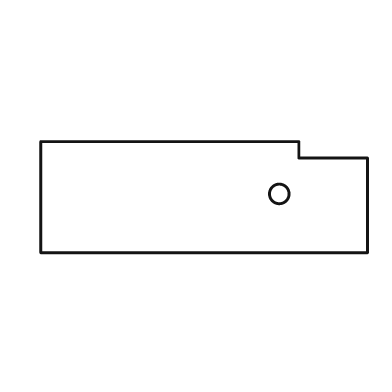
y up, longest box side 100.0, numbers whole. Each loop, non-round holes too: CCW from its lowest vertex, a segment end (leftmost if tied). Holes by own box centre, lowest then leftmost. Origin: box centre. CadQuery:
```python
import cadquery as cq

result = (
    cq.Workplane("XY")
    .moveTo(-50.0, -17.0)
    .lineTo(50.0, -17.0)
    .lineTo(50.0, 12.0)
    .lineTo(29.0, 12.0)
    .lineTo(29.0, 17.0)
    .lineTo(-50.0, 17.0)
    .close()
    .moveTo(23.0, 1.0)
    .circle(3.0)
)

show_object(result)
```